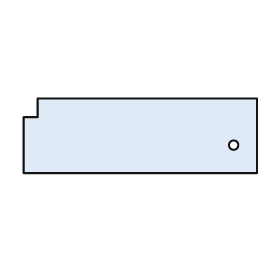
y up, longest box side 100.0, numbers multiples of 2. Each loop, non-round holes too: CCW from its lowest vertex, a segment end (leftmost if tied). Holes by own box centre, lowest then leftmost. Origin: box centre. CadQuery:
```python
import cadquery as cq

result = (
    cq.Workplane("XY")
    .moveTo(-50.0, -16.0)
    .lineTo(50.0, -16.0)
    .lineTo(50.0, 16.0)
    .lineTo(-44.0, 16.0)
    .lineTo(-44.0, 8.0)
    .lineTo(-50.0, 8.0)
    .close()
    .moveTo(40.0, -4.0)
    .circle(2.0)
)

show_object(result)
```